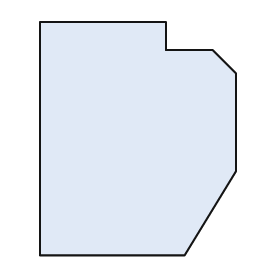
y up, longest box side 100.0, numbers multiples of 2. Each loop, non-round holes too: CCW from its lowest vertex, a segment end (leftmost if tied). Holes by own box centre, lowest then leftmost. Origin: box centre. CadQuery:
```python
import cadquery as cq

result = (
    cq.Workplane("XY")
    .moveTo(-42.0, -50.0)
    .lineTo(20.0, -50.0)
    .lineTo(42.0, -14.0)
    .lineTo(42.0, 28.0)
    .lineTo(32.0, 38.0)
    .lineTo(12.0, 38.0)
    .lineTo(12.0, 50.0)
    .lineTo(-42.0, 50.0)
    .close()
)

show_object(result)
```